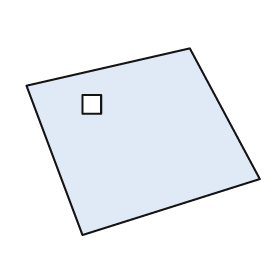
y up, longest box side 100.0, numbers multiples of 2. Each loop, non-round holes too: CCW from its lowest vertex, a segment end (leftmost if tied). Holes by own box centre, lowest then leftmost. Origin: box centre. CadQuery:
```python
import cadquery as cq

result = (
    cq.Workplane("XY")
    .moveTo(-26.0, -40.0)
    .lineTo(50.0, -16.0)
    .lineTo(20.0, 40.0)
    .lineTo(-50.0, 24.0)
    .close()
    .moveTo(-26.0, 12.0)
    .lineTo(-18.0, 12.0)
    .lineTo(-18.0, 20.0)
    .lineTo(-26.0, 20.0)
    .close()
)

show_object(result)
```